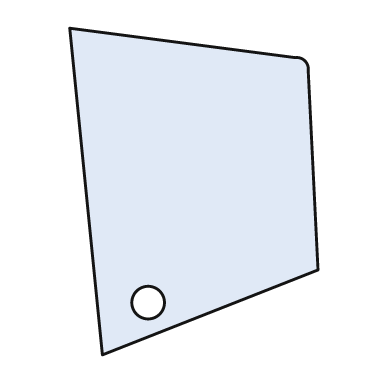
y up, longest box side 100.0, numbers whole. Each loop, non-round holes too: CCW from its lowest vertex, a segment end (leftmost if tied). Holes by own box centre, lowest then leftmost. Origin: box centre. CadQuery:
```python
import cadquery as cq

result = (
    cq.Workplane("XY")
    .moveTo(-28.0, -50.0)
    .lineTo(38.0, -24.0)
    .lineTo(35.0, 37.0)
    .threePointArc((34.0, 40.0), (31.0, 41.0))
    .lineTo(-38.0, 50.0)
    .close()
    .moveTo(-14.0, -34.0)
    .circle(5.0)
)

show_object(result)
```